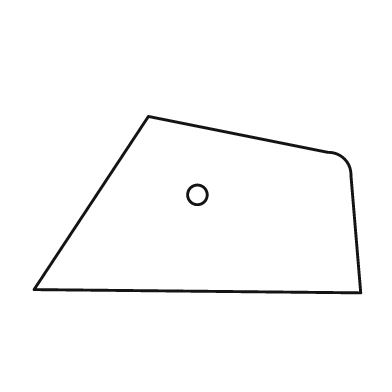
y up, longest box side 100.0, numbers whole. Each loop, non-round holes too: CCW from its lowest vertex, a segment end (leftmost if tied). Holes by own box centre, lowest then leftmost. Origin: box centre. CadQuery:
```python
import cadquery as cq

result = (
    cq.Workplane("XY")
    .moveTo(50.0, -27.0)
    .lineTo(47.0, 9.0)
    .threePointArc((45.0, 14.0), (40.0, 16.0))
    .lineTo(-15.0, 27.0)
    .lineTo(-50.0, -26.0)
    .close()
    .moveTo(0.0, 3.0)
    .circle(3.0)
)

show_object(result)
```